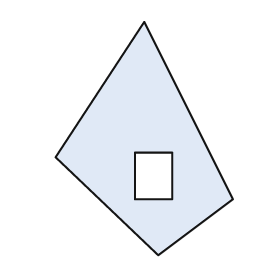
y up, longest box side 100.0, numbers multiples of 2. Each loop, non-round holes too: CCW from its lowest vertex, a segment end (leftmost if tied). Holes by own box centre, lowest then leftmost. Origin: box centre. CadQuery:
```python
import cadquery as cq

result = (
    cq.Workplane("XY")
    .moveTo(6.0, -50.0)
    .lineTo(38.0, -26.0)
    .lineTo(0.0, 50.0)
    .lineTo(-38.0, -8.0)
    .close()
    .moveTo(-4.0, -26.0)
    .lineTo(12.0, -26.0)
    .lineTo(12.0, -6.0)
    .lineTo(-4.0, -6.0)
    .close()
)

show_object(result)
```